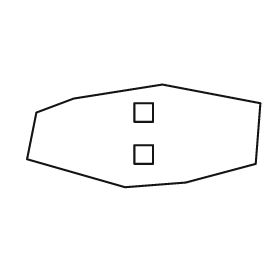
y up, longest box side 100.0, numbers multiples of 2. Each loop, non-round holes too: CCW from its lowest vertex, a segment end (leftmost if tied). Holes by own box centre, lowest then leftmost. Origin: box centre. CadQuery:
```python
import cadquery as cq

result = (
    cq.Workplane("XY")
    .moveTo(-8.0, -22.0)
    .lineTo(18.0, -20.0)
    .lineTo(48.0, -12.0)
    .lineTo(50.0, 14.0)
    .lineTo(8.0, 22.0)
    .lineTo(-30.0, 16.0)
    .lineTo(-46.0, 10.0)
    .lineTo(-50.0, -10.0)
    .close()
    .moveTo(-4.0, -12.0)
    .lineTo(4.0, -12.0)
    .lineTo(4.0, -4.0)
    .lineTo(-4.0, -4.0)
    .close()
    .moveTo(-4.0, 6.0)
    .lineTo(4.0, 6.0)
    .lineTo(4.0, 14.0)
    .lineTo(-4.0, 14.0)
    .close()
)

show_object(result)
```